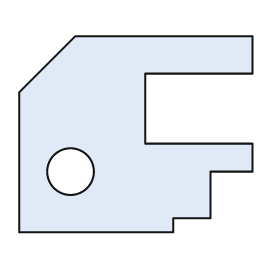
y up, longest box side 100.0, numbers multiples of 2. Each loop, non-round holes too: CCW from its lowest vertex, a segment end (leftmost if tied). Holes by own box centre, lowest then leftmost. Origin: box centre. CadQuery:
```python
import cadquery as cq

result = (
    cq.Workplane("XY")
    .moveTo(-50.0, -42.0)
    .lineTo(16.0, -42.0)
    .lineTo(16.0, -36.0)
    .lineTo(32.0, -36.0)
    .lineTo(32.0, -16.0)
    .lineTo(50.0, -16.0)
    .lineTo(50.0, -4.0)
    .lineTo(4.0, -4.0)
    .lineTo(4.0, 26.0)
    .lineTo(50.0, 26.0)
    .lineTo(50.0, 42.0)
    .lineTo(-26.0, 42.0)
    .lineTo(-50.0, 18.0)
    .close()
    .moveTo(-28.0, -16.0)
    .circle(10.0)
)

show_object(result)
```